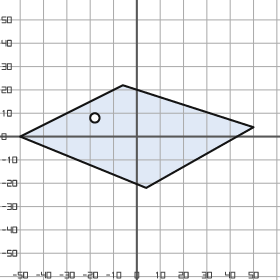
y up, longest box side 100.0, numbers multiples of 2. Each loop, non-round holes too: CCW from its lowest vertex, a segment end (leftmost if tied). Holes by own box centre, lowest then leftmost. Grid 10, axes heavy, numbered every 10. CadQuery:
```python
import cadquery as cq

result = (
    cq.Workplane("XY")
    .moveTo(4.0, -22.0)
    .lineTo(50.0, 4.0)
    .lineTo(-6.0, 22.0)
    .lineTo(-50.0, 0.0)
    .close()
    .moveTo(-18.0, 8.0)
    .circle(2.0)
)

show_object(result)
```